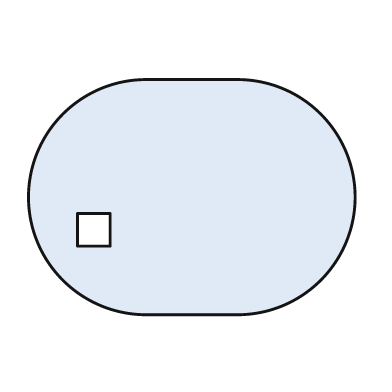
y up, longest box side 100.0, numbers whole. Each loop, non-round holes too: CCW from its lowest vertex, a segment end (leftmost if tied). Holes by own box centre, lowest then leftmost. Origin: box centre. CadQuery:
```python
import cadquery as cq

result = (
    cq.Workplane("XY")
    .moveTo(-14.0, -36.0)
    .lineTo(14.0, -36.0)
    .threePointArc((50.0, 0.0), (14.0, 36.0))
    .lineTo(-14.0, 36.0)
    .threePointArc((-50.0, 0.0), (-14.0, -36.0))
    .close()
    .moveTo(-35.0, -15.0)
    .lineTo(-25.0, -15.0)
    .lineTo(-25.0, -5.0)
    .lineTo(-35.0, -5.0)
    .close()
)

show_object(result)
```